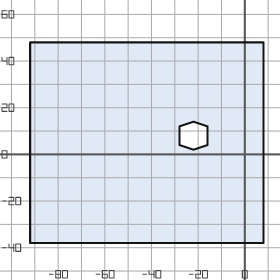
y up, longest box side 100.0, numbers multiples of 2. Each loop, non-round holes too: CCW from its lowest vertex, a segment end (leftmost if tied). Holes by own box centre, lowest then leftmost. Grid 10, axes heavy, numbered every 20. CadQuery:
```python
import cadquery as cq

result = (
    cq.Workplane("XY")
    .moveTo(-92.0, -38.0)
    .lineTo(8.0, -38.0)
    .lineTo(8.0, 48.0)
    .lineTo(-92.0, 48.0)
    .close()
    .moveTo(-22.0, 2.0)
    .lineTo(-16.0, 4.0)
    .lineTo(-16.0, 12.0)
    .lineTo(-22.0, 14.0)
    .lineTo(-28.0, 12.0)
    .lineTo(-28.0, 4.0)
    .close()
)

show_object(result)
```